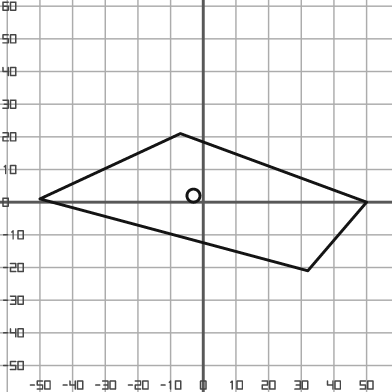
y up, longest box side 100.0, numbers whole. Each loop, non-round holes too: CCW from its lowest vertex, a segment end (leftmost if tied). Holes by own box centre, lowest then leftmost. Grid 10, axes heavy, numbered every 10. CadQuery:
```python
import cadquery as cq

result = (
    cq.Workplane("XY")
    .moveTo(32.0, -21.0)
    .lineTo(50.0, 0.0)
    .lineTo(-7.0, 21.0)
    .lineTo(-50.0, 1.0)
    .close()
    .moveTo(-3.0, 2.0)
    .circle(2.0)
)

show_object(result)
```